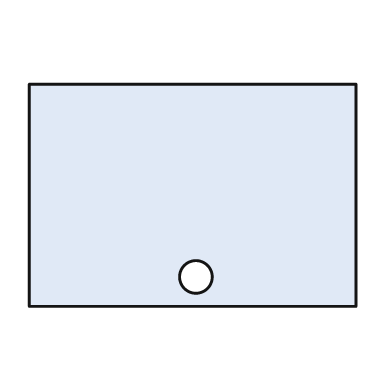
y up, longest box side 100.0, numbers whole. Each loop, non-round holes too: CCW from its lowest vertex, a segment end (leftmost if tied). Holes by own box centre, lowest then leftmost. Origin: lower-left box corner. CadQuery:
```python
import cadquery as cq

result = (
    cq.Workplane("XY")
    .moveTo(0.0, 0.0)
    .lineTo(100.0, 0.0)
    .lineTo(100.0, 68.0)
    .lineTo(0.0, 68.0)
    .close()
    .moveTo(51.0, 9.0)
    .circle(5.0)
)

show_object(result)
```